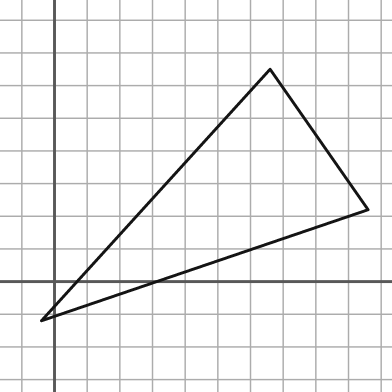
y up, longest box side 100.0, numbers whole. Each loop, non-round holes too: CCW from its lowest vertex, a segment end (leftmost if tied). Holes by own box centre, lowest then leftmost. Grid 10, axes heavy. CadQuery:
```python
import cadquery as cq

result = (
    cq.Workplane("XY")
    .moveTo(-4.0, -12.0)
    .lineTo(96.0, 22.0)
    .lineTo(66.0, 65.0)
    .close()
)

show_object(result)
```